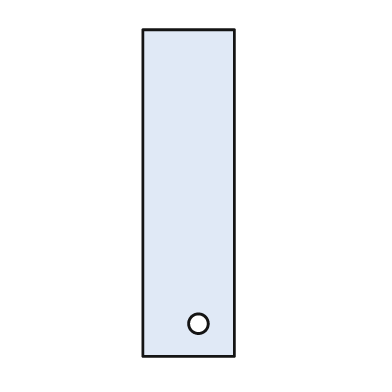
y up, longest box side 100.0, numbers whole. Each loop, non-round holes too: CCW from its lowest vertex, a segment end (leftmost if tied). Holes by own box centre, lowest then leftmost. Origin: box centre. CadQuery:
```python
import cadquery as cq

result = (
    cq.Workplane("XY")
    .moveTo(-14.0, -50.0)
    .lineTo(14.0, -50.0)
    .lineTo(14.0, 50.0)
    .lineTo(-14.0, 50.0)
    .close()
    .moveTo(3.0, -40.0)
    .circle(3.0)
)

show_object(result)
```